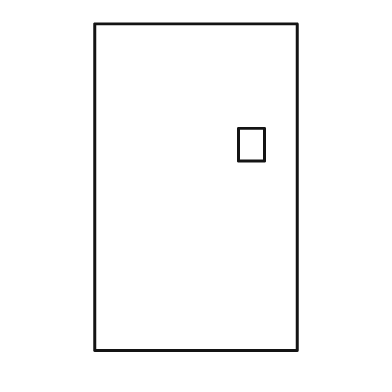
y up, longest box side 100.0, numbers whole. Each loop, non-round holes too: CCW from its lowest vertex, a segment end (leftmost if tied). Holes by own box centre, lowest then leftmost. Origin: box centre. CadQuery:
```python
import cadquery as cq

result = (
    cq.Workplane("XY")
    .moveTo(-31.0, -50.0)
    .lineTo(31.0, -50.0)
    .lineTo(31.0, 50.0)
    .lineTo(-31.0, 50.0)
    .close()
    .moveTo(13.0, 8.0)
    .lineTo(21.0, 8.0)
    .lineTo(21.0, 18.0)
    .lineTo(13.0, 18.0)
    .close()
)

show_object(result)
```